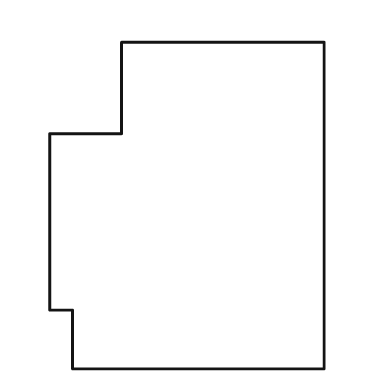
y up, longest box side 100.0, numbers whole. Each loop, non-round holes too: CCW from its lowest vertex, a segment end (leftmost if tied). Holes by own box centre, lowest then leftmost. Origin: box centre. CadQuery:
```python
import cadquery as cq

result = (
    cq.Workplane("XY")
    .moveTo(-35.0, -50.0)
    .lineTo(42.0, -50.0)
    .lineTo(42.0, 50.0)
    .lineTo(-20.0, 50.0)
    .lineTo(-20.0, 22.0)
    .lineTo(-42.0, 22.0)
    .lineTo(-42.0, -32.0)
    .lineTo(-35.0, -32.0)
    .close()
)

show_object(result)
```